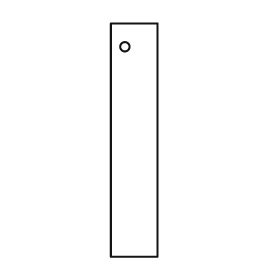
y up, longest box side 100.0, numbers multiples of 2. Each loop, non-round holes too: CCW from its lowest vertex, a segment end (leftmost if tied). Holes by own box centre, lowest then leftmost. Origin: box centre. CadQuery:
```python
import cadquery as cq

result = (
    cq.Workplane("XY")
    .moveTo(-10.0, -50.0)
    .lineTo(10.0, -50.0)
    .lineTo(10.0, 50.0)
    .lineTo(-10.0, 50.0)
    .close()
    .moveTo(-4.0, 40.0)
    .circle(2.0)
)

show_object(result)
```